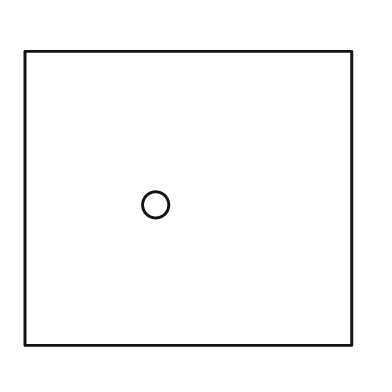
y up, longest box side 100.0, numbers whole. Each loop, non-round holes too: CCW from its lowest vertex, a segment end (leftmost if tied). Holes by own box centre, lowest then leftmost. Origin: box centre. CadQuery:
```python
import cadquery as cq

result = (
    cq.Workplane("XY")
    .moveTo(-50.0, -45.0)
    .lineTo(50.0, -45.0)
    .lineTo(50.0, 45.0)
    .lineTo(-50.0, 45.0)
    .close()
    .moveTo(-10.0, -2.0)
    .circle(4.0)
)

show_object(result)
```